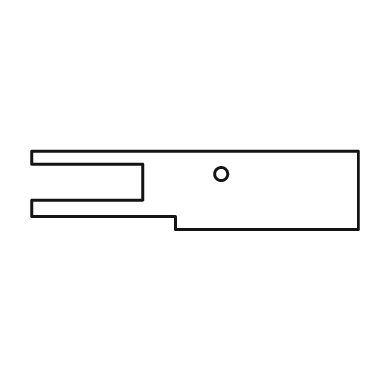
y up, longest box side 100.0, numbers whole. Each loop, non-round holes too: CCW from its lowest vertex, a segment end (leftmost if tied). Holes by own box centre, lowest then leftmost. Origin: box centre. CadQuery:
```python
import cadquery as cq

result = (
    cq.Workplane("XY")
    .moveTo(-6.0, -12.0)
    .lineTo(50.0, -12.0)
    .lineTo(50.0, 12.0)
    .lineTo(-50.0, 12.0)
    .lineTo(-50.0, 8.0)
    .lineTo(-16.0, 8.0)
    .lineTo(-16.0, -3.0)
    .lineTo(-50.0, -3.0)
    .lineTo(-50.0, -8.0)
    .lineTo(-6.0, -8.0)
    .close()
    .moveTo(8.0, 5.0)
    .circle(2.0)
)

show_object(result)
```